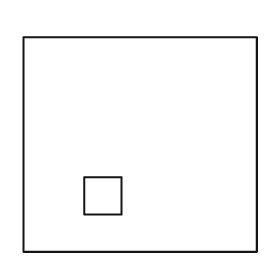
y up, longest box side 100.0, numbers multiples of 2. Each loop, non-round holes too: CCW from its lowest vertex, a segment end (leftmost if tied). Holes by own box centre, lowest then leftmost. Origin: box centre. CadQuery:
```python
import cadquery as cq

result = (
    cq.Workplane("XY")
    .moveTo(-50.0, -46.0)
    .lineTo(50.0, -46.0)
    .lineTo(50.0, 46.0)
    .lineTo(-50.0, 46.0)
    .close()
    .moveTo(-24.0, -30.0)
    .lineTo(-8.0, -30.0)
    .lineTo(-8.0, -14.0)
    .lineTo(-24.0, -14.0)
    .close()
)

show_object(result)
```